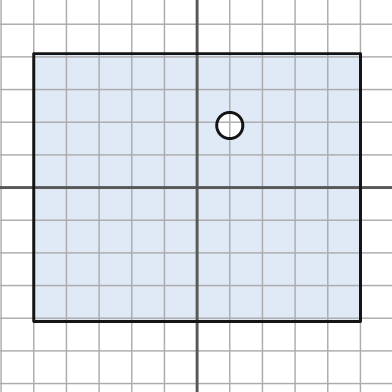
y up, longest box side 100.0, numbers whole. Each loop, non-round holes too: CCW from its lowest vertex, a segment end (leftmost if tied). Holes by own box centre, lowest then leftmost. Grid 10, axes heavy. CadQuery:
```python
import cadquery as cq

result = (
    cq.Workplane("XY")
    .moveTo(-50.0, -41.0)
    .lineTo(50.0, -41.0)
    .lineTo(50.0, 41.0)
    .lineTo(-50.0, 41.0)
    .close()
    .moveTo(10.0, 19.0)
    .circle(4.0)
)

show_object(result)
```